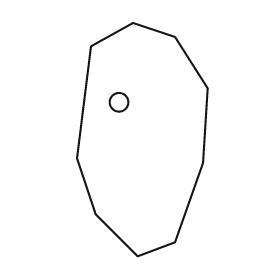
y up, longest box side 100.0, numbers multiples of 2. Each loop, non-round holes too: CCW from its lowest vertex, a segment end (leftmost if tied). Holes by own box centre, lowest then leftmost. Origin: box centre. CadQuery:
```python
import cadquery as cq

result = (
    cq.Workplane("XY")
    .moveTo(-2.0, -50.0)
    .lineTo(14.0, -44.0)
    .lineTo(26.0, -10.0)
    .lineTo(28.0, 22.0)
    .lineTo(14.0, 44.0)
    .lineTo(-4.0, 50.0)
    .lineTo(-22.0, 40.0)
    .lineTo(-28.0, -8.0)
    .lineTo(-20.0, -32.0)
    .close()
    .moveTo(-10.0, 16.0)
    .circle(4.0)
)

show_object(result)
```